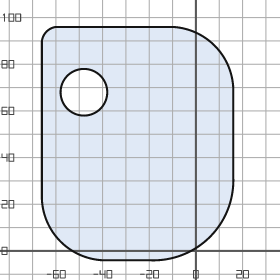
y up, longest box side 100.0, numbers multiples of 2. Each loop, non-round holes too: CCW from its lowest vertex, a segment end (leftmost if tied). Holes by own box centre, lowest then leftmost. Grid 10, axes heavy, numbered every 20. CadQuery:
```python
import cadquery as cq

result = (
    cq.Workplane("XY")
    .moveTo(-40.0, -4.0)
    .lineTo(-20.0, -4.0)
    .threePointArc((6.0, 6.0), (16.0, 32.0))
    .lineTo(16.0, 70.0)
    .threePointArc((8.0, 88.0), (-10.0, 96.0))
    .lineTo(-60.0, 96.0)
    .threePointArc((-64.0, 94.0), (-66.0, 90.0))
    .lineTo(-66.0, 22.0)
    .threePointArc((-58.0, 4.0), (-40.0, -4.0))
    .close()
    .moveTo(-48.0, 68.0)
    .circle(10.0)
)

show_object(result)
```